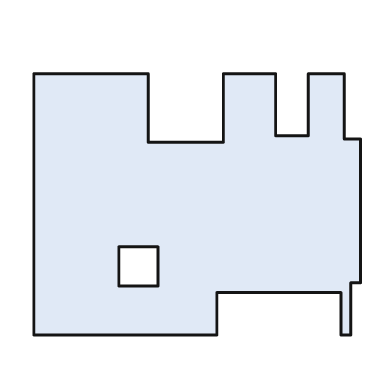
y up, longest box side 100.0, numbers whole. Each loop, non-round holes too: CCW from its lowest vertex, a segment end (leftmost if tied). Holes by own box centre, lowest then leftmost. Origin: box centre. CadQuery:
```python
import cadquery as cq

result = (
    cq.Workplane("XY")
    .moveTo(-50.0, -40.0)
    .lineTo(6.0, -40.0)
    .lineTo(6.0, -27.0)
    .lineTo(44.0, -27.0)
    .lineTo(44.0, -40.0)
    .lineTo(47.0, -40.0)
    .lineTo(47.0, -24.0)
    .lineTo(50.0, -24.0)
    .lineTo(50.0, 20.0)
    .lineTo(45.0, 20.0)
    .lineTo(45.0, 40.0)
    .lineTo(34.0, 40.0)
    .lineTo(34.0, 21.0)
    .lineTo(24.0, 21.0)
    .lineTo(24.0, 40.0)
    .lineTo(8.0, 40.0)
    .lineTo(8.0, 19.0)
    .lineTo(-15.0, 19.0)
    .lineTo(-15.0, 40.0)
    .lineTo(-50.0, 40.0)
    .close()
    .moveTo(-24.0, -25.0)
    .lineTo(-12.0, -25.0)
    .lineTo(-12.0, -13.0)
    .lineTo(-24.0, -13.0)
    .close()
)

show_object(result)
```